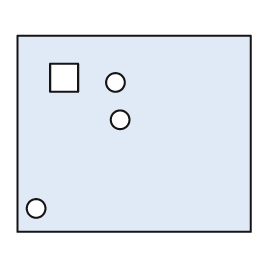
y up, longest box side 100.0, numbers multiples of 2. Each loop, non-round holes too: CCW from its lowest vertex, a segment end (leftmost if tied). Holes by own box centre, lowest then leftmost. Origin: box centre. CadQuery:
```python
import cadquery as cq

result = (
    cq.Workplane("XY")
    .moveTo(-50.0, -42.0)
    .lineTo(50.0, -42.0)
    .lineTo(50.0, 42.0)
    .lineTo(-50.0, 42.0)
    .close()
    .moveTo(-42.0, -32.0)
    .circle(4.0)
    .moveTo(-6.0, 6.0)
    .circle(4.0)
    .moveTo(-8.0, 22.0)
    .circle(4.0)
    .moveTo(-36.0, 18.0)
    .lineTo(-24.0, 18.0)
    .lineTo(-24.0, 30.0)
    .lineTo(-36.0, 30.0)
    .close()
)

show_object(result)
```